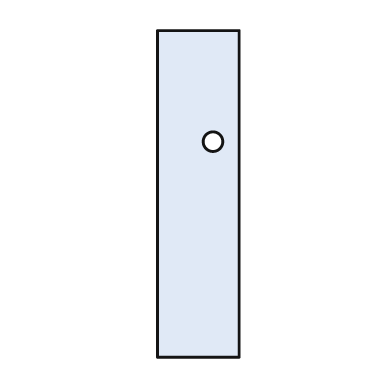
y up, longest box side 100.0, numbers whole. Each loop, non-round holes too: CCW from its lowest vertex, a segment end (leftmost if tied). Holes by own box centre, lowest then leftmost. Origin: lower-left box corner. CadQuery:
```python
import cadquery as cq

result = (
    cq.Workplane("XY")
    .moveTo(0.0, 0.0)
    .lineTo(25.0, 0.0)
    .lineTo(25.0, 100.0)
    .lineTo(0.0, 100.0)
    .close()
    .moveTo(17.0, 66.0)
    .circle(3.0)
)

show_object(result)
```